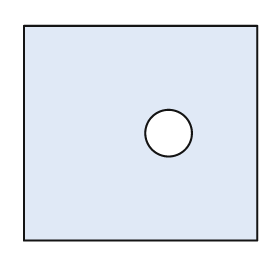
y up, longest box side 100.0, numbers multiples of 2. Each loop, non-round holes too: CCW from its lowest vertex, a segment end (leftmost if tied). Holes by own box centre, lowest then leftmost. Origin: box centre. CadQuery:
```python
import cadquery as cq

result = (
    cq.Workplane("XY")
    .moveTo(-50.0, -46.0)
    .lineTo(50.0, -46.0)
    .lineTo(50.0, 46.0)
    .lineTo(-50.0, 46.0)
    .close()
    .moveTo(12.0, 0.0)
    .circle(10.0)
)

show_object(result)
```